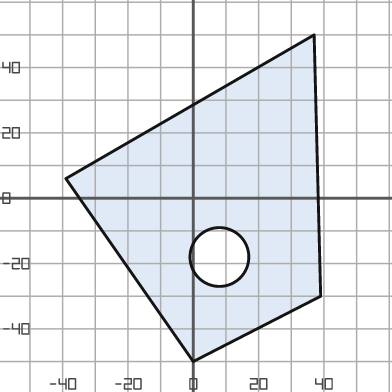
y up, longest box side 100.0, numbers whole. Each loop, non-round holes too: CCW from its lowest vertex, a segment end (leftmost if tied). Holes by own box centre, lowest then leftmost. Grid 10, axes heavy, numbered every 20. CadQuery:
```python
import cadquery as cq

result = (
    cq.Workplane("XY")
    .moveTo(0.0, -50.0)
    .lineTo(39.0, -30.0)
    .lineTo(37.0, 50.0)
    .lineTo(-39.0, 6.0)
    .close()
    .moveTo(8.0, -18.0)
    .circle(9.0)
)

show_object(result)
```